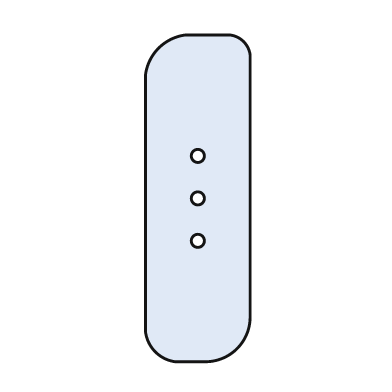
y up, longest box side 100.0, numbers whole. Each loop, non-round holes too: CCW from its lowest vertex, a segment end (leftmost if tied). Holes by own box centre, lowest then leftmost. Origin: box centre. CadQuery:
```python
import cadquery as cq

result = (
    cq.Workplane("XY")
    .moveTo(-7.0, -50.0)
    .lineTo(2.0, -50.0)
    .threePointArc((12.0, -46.0), (16.0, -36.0))
    .lineTo(16.0, 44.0)
    .threePointArc((14.0, 48.0), (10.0, 50.0))
    .lineTo(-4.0, 50.0)
    .threePointArc((-12.0, 46.0), (-16.0, 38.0))
    .lineTo(-16.0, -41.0)
    .threePointArc((-13.0, -47.0), (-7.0, -50.0))
    .close()
    .moveTo(0.0, -13.0)
    .circle(2.0)
    .moveTo(0.0, 0.0)
    .circle(2.0)
    .moveTo(0.0, 13.0)
    .circle(2.0)
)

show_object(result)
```